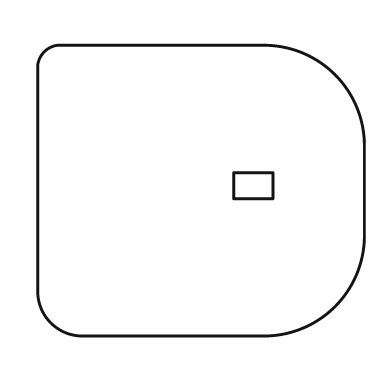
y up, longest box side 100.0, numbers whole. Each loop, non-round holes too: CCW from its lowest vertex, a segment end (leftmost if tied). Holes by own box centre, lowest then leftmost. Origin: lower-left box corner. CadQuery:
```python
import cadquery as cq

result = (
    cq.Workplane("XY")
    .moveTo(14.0, 0.0)
    .lineTo(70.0, 0.0)
    .threePointArc((91.0, 9.0), (100.0, 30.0))
    .lineTo(100.0, 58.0)
    .threePointArc((91.0, 80.0), (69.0, 89.0))
    .lineTo(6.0, 89.0)
    .threePointArc((2.0, 87.0), (0.0, 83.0))
    .lineTo(0.0, 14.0)
    .threePointArc((4.0, 4.0), (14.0, 0.0))
    .close()
    .moveTo(60.0, 42.0)
    .lineTo(72.0, 42.0)
    .lineTo(72.0, 50.0)
    .lineTo(60.0, 50.0)
    .close()
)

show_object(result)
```